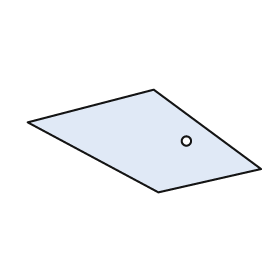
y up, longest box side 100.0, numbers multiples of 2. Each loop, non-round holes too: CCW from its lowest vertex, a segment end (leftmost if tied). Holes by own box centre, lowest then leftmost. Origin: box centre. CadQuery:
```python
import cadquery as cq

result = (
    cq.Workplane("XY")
    .moveTo(6.0, -22.0)
    .lineTo(50.0, -12.0)
    .lineTo(4.0, 22.0)
    .lineTo(-50.0, 8.0)
    .close()
    .moveTo(18.0, 0.0)
    .circle(2.0)
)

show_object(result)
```